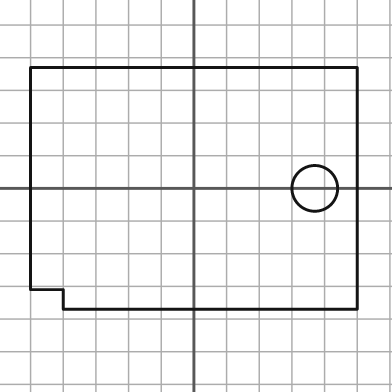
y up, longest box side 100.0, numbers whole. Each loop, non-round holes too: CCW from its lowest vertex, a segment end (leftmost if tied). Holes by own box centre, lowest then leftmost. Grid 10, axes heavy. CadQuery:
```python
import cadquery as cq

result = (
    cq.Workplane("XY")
    .moveTo(-40.0, -37.0)
    .lineTo(50.0, -37.0)
    .lineTo(50.0, 37.0)
    .lineTo(-50.0, 37.0)
    .lineTo(-50.0, -31.0)
    .lineTo(-40.0, -31.0)
    .close()
    .moveTo(37.0, 0.0)
    .circle(7.0)
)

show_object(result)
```